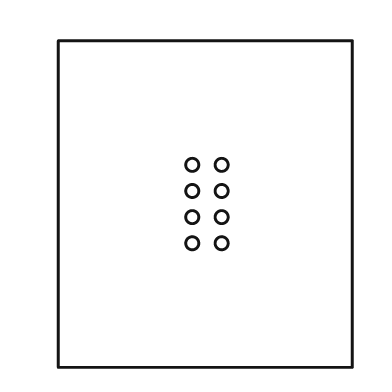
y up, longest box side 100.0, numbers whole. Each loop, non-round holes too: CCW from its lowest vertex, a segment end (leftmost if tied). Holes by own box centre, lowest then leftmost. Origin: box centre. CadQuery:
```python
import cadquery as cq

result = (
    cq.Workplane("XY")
    .moveTo(-45.0, -50.0)
    .lineTo(45.0, -50.0)
    .lineTo(45.0, 50.0)
    .lineTo(-45.0, 50.0)
    .close()
    .moveTo(-4.0, -12.0)
    .circle(2.0)
    .moveTo(5.0, -12.0)
    .circle(2.0)
    .moveTo(-4.0, -4.0)
    .circle(2.0)
    .moveTo(5.0, -4.0)
    .circle(2.0)
    .moveTo(-4.0, 4.0)
    .circle(2.0)
    .moveTo(5.0, 4.0)
    .circle(2.0)
    .moveTo(-4.0, 12.0)
    .circle(2.0)
    .moveTo(5.0, 12.0)
    .circle(2.0)
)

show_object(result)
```